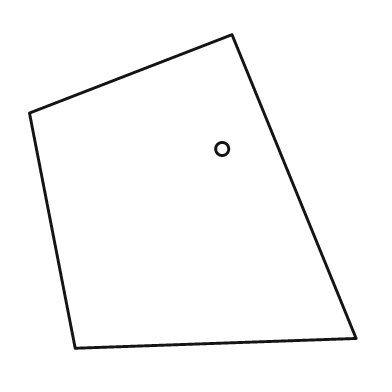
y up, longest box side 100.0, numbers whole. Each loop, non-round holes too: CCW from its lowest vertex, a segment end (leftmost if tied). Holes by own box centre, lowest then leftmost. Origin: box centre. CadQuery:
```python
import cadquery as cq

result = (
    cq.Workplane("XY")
    .moveTo(-36.0, -48.0)
    .lineTo(50.0, -45.0)
    .lineTo(12.0, 48.0)
    .lineTo(-50.0, 24.0)
    .close()
    .moveTo(9.0, 13.0)
    .circle(2.0)
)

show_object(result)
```